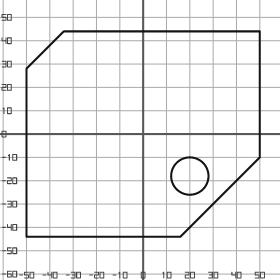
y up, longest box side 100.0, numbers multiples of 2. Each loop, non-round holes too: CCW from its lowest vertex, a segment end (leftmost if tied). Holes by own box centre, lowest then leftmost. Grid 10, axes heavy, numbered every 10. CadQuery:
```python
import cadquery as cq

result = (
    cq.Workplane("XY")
    .moveTo(-50.0, -44.0)
    .lineTo(16.0, -44.0)
    .lineTo(50.0, -10.0)
    .lineTo(50.0, 44.0)
    .lineTo(-34.0, 44.0)
    .lineTo(-50.0, 28.0)
    .close()
    .moveTo(20.0, -18.0)
    .circle(8.0)
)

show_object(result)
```